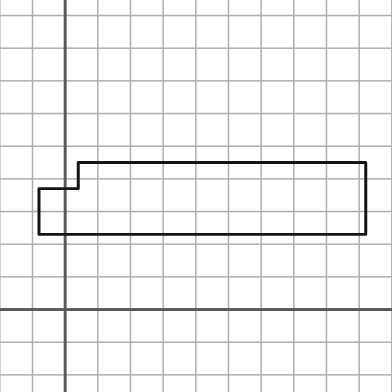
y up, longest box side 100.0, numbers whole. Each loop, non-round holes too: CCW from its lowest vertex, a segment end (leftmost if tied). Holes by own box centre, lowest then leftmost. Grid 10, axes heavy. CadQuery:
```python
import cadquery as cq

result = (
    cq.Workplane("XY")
    .moveTo(-8.0, 23.0)
    .lineTo(92.0, 23.0)
    .lineTo(92.0, 45.0)
    .lineTo(4.0, 45.0)
    .lineTo(4.0, 37.0)
    .lineTo(-8.0, 37.0)
    .close()
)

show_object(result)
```